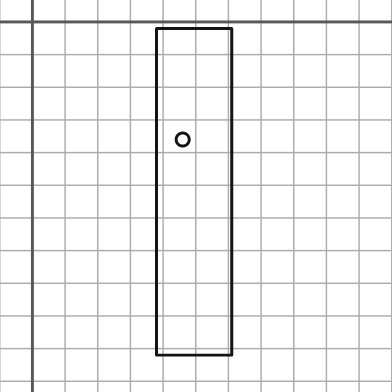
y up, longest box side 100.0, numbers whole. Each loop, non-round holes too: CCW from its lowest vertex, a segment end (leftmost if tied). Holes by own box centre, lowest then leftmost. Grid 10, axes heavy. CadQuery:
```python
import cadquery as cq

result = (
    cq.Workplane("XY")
    .moveTo(38.0, -102.0)
    .lineTo(61.0, -102.0)
    .lineTo(61.0, -2.0)
    .lineTo(38.0, -2.0)
    .close()
    .moveTo(46.0, -36.0)
    .circle(2.0)
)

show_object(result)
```